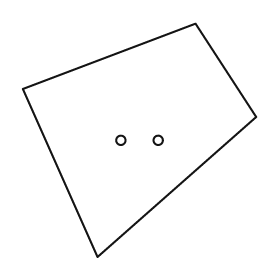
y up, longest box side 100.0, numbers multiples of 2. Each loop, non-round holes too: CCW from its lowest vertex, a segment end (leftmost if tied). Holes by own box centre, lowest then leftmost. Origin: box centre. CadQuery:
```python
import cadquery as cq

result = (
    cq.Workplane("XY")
    .moveTo(-18.0, -50.0)
    .lineTo(50.0, 10.0)
    .lineTo(24.0, 50.0)
    .lineTo(-50.0, 22.0)
    .close()
    .moveTo(-8.0, 0.0)
    .circle(2.0)
    .moveTo(8.0, 0.0)
    .circle(2.0)
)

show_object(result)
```